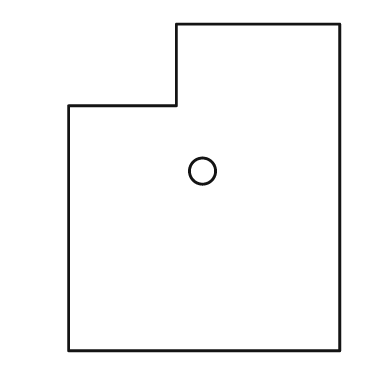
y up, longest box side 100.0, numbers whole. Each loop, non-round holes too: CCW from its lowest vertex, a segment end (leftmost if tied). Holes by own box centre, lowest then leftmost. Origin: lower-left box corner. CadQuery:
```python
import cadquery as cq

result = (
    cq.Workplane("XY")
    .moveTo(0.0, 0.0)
    .lineTo(83.0, 0.0)
    .lineTo(83.0, 100.0)
    .lineTo(33.0, 100.0)
    .lineTo(33.0, 75.0)
    .lineTo(0.0, 75.0)
    .close()
    .moveTo(41.0, 55.0)
    .circle(4.0)
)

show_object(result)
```